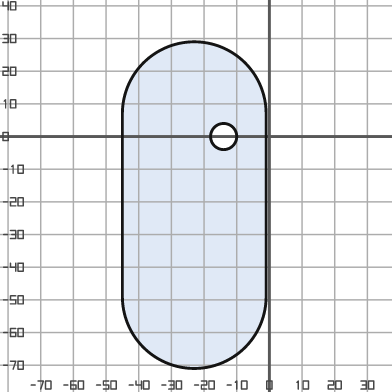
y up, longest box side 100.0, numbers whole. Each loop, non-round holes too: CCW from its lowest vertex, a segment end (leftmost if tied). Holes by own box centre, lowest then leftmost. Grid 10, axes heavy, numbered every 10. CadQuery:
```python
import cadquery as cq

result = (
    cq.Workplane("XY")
    .moveTo(-45.0, -49.0)
    .threePointArc((-23.0, -71.0), (-1.0, -49.0))
    .lineTo(-1.0, 7.0)
    .threePointArc((-23.0, 29.0), (-45.0, 7.0))
    .close()
    .moveTo(-14.0, 0.0)
    .circle(4.0)
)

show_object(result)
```